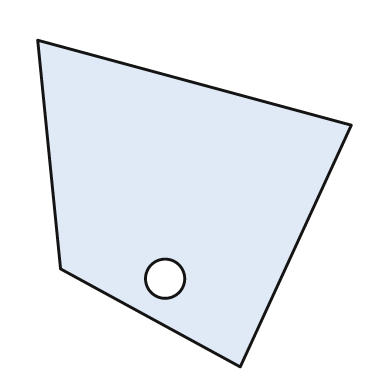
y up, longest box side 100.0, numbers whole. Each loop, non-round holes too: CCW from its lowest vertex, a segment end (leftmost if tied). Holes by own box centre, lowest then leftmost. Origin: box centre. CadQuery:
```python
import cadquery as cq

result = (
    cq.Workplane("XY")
    .moveTo(14.0, -50.0)
    .lineTo(48.0, 24.0)
    .lineTo(-48.0, 50.0)
    .lineTo(-41.0, -20.0)
    .close()
    .moveTo(-9.0, -23.0)
    .circle(6.0)
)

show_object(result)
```